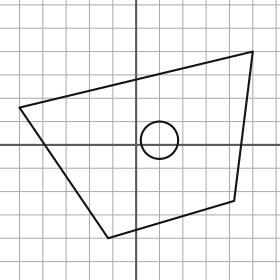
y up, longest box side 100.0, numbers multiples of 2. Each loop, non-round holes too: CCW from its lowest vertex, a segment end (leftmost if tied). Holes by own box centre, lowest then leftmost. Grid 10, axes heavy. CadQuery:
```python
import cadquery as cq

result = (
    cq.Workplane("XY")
    .moveTo(-12.0, -40.0)
    .lineTo(42.0, -24.0)
    .lineTo(50.0, 40.0)
    .lineTo(-50.0, 16.0)
    .close()
    .moveTo(10.0, 2.0)
    .circle(8.0)
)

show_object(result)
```